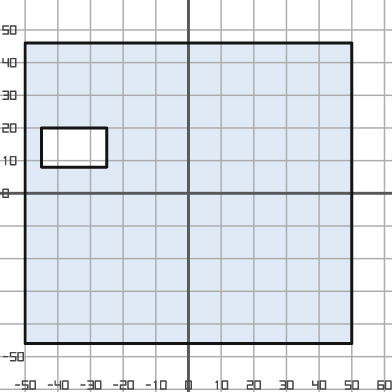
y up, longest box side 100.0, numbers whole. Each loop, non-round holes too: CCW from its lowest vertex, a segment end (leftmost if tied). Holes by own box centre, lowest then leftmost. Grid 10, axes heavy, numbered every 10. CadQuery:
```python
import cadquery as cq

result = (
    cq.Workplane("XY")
    .moveTo(-50.0, -46.0)
    .lineTo(50.0, -46.0)
    .lineTo(50.0, 46.0)
    .lineTo(-50.0, 46.0)
    .close()
    .moveTo(-45.0, 8.0)
    .lineTo(-25.0, 8.0)
    .lineTo(-25.0, 20.0)
    .lineTo(-45.0, 20.0)
    .close()
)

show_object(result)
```